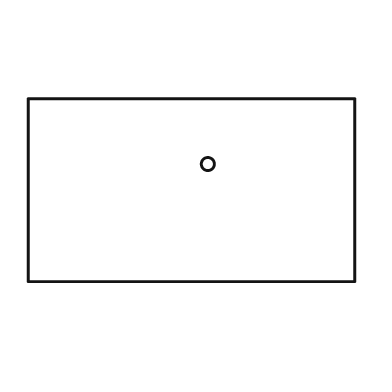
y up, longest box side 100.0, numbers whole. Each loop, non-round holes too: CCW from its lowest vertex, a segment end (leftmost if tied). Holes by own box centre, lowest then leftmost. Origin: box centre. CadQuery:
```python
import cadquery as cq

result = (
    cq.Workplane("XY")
    .moveTo(-50.0, -28.0)
    .lineTo(50.0, -28.0)
    .lineTo(50.0, 28.0)
    .lineTo(-50.0, 28.0)
    .close()
    .moveTo(5.0, 8.0)
    .circle(2.0)
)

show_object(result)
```